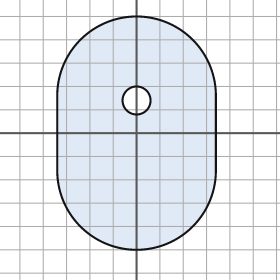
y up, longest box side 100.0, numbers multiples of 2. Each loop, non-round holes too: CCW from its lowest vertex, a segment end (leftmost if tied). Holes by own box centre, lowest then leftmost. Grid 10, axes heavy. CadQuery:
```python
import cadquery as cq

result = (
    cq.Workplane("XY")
    .moveTo(-34.0, -16.0)
    .threePointArc((0.0, -50.0), (34.0, -16.0))
    .lineTo(34.0, 16.0)
    .threePointArc((0.0, 50.0), (-34.0, 16.0))
    .close()
    .moveTo(0.0, 14.0)
    .circle(6.0)
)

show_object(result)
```